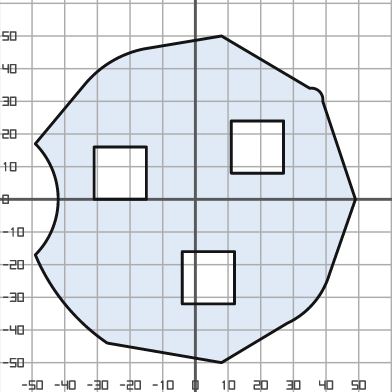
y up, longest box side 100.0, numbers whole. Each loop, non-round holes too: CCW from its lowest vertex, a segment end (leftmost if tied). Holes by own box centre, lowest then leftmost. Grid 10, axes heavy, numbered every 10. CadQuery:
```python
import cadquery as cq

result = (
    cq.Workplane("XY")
    .moveTo(8.0, -50.0)
    .lineTo(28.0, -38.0)
    .threePointArc((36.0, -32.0), (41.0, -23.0))
    .lineTo(49.0, 0.0)
    .lineTo(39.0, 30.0)
    .threePointArc((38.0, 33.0), (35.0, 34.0))
    .lineTo(8.0, 50.0)
    .lineTo(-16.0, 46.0)
    .threePointArc((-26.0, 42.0), (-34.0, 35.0))
    .lineTo(-49.0, 17.0)
    .threePointArc((-42.0, 0.0), (-49.0, -17.0))
    .threePointArc((-40.0, -32.0), (-27.0, -44.0))
    .close()
    .moveTo(-4.0, -32.0)
    .lineTo(12.0, -32.0)
    .lineTo(12.0, -16.0)
    .lineTo(-4.0, -16.0)
    .close()
    .moveTo(-31.0, 0.0)
    .lineTo(-15.0, 0.0)
    .lineTo(-15.0, 16.0)
    .lineTo(-31.0, 16.0)
    .close()
    .moveTo(11.0, 8.0)
    .lineTo(27.0, 8.0)
    .lineTo(27.0, 24.0)
    .lineTo(11.0, 24.0)
    .close()
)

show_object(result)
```